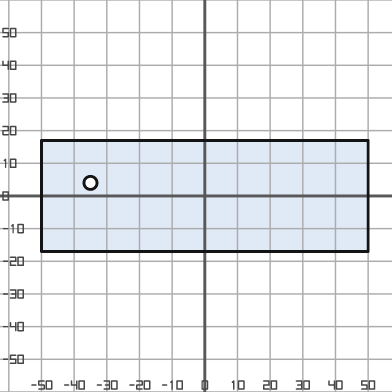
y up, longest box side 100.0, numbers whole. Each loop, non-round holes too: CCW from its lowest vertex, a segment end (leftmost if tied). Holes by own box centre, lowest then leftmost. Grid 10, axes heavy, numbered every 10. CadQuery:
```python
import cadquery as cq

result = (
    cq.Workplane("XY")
    .moveTo(-50.0, -17.0)
    .lineTo(50.0, -17.0)
    .lineTo(50.0, 17.0)
    .lineTo(-50.0, 17.0)
    .close()
    .moveTo(-35.0, 4.0)
    .circle(2.0)
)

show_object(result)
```